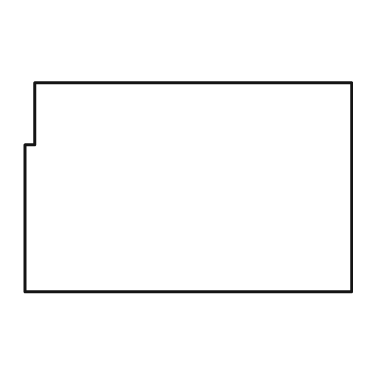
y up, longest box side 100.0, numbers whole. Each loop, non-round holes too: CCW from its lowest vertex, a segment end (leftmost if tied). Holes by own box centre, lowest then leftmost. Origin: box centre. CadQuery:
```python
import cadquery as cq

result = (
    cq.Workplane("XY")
    .moveTo(-50.0, -32.0)
    .lineTo(50.0, -32.0)
    .lineTo(50.0, 32.0)
    .lineTo(-47.0, 32.0)
    .lineTo(-47.0, 13.0)
    .lineTo(-50.0, 13.0)
    .close()
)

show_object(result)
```